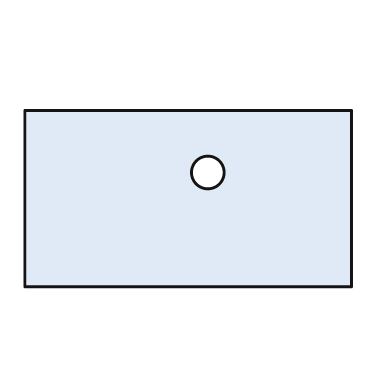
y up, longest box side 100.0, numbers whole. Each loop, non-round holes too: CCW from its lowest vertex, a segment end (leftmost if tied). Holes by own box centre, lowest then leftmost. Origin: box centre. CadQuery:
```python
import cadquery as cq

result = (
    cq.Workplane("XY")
    .moveTo(-50.0, -27.0)
    .lineTo(50.0, -27.0)
    .lineTo(50.0, 27.0)
    .lineTo(-50.0, 27.0)
    .close()
    .moveTo(6.0, 8.0)
    .circle(5.0)
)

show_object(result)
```